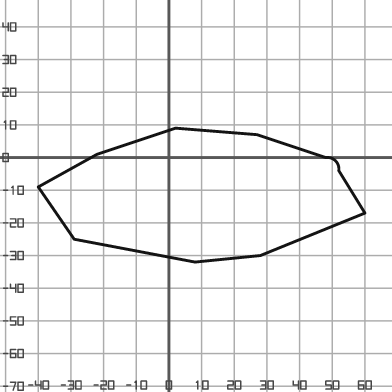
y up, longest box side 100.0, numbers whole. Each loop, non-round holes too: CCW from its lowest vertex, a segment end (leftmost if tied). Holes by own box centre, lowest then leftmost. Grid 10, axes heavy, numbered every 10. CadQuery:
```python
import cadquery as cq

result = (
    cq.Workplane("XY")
    .moveTo(8.0, -32.0)
    .lineTo(28.0, -30.0)
    .lineTo(60.0, -17.0)
    .lineTo(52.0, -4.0)
    .threePointArc((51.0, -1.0), (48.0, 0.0))
    .lineTo(27.0, 7.0)
    .lineTo(2.0, 9.0)
    .lineTo(-22.0, 1.0)
    .lineTo(-40.0, -9.0)
    .lineTo(-29.0, -25.0)
    .close()
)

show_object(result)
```